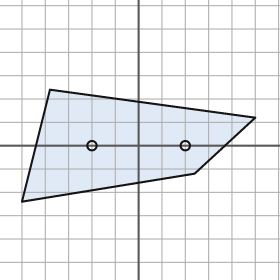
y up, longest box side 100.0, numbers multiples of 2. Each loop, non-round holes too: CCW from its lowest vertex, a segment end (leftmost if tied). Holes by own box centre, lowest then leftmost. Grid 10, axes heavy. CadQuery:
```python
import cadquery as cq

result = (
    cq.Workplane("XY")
    .moveTo(-50.0, -24.0)
    .lineTo(24.0, -12.0)
    .lineTo(50.0, 12.0)
    .lineTo(-38.0, 24.0)
    .close()
    .moveTo(-20.0, 0.0)
    .circle(2.0)
    .moveTo(20.0, 0.0)
    .circle(2.0)
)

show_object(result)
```